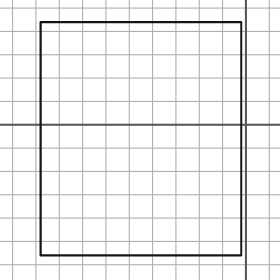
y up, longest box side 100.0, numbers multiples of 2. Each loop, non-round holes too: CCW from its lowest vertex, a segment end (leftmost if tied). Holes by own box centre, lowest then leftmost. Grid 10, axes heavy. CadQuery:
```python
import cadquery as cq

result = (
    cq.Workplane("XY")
    .moveTo(-88.0, -56.0)
    .lineTo(-2.0, -56.0)
    .lineTo(-2.0, 44.0)
    .lineTo(-88.0, 44.0)
    .close()
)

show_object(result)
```